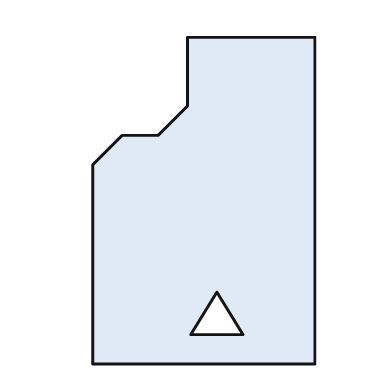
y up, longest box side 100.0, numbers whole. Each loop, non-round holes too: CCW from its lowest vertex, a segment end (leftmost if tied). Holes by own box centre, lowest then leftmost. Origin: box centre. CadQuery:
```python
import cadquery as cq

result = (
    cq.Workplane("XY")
    .moveTo(-34.0, -50.0)
    .lineTo(34.0, -50.0)
    .lineTo(34.0, 50.0)
    .lineTo(-5.0, 50.0)
    .lineTo(-5.0, 29.0)
    .lineTo(-14.0, 20.0)
    .lineTo(-25.0, 20.0)
    .lineTo(-34.0, 11.0)
    .close()
    .moveTo(-4.0, -41.0)
    .lineTo(12.0, -41.0)
    .lineTo(4.0, -28.0)
    .close()
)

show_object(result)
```